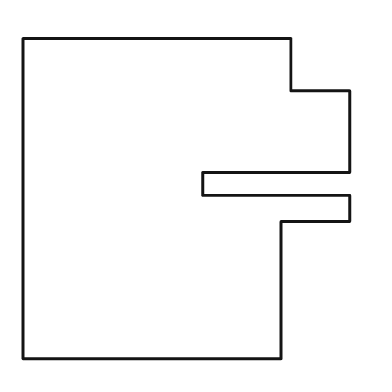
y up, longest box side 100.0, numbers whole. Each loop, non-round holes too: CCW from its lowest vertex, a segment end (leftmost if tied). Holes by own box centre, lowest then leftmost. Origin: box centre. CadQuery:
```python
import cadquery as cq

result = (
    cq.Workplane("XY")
    .moveTo(-50.0, -49.0)
    .lineTo(29.0, -49.0)
    .lineTo(29.0, -7.0)
    .lineTo(50.0, -7.0)
    .lineTo(50.0, 1.0)
    .lineTo(5.0, 1.0)
    .lineTo(5.0, 8.0)
    .lineTo(50.0, 8.0)
    .lineTo(50.0, 33.0)
    .lineTo(32.0, 33.0)
    .lineTo(32.0, 49.0)
    .lineTo(-50.0, 49.0)
    .close()
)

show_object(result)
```